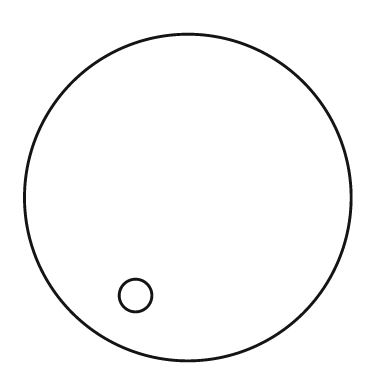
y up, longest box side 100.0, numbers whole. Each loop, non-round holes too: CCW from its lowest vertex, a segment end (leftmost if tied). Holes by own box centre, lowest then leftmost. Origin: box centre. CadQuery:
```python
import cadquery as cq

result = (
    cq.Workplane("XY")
    .moveTo(0.0, 0.0)
    .circle(50.0)
    .moveTo(-16.0, -30.0)
    .circle(5.0)
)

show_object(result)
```